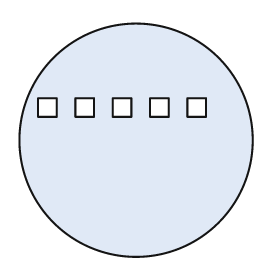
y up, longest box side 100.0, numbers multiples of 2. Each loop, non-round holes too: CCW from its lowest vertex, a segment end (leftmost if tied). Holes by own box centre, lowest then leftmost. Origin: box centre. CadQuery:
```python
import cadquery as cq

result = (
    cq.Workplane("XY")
    .moveTo(0.0, 0.0)
    .circle(50.0)
    .moveTo(-42.0, 10.0)
    .lineTo(-34.0, 10.0)
    .lineTo(-34.0, 18.0)
    .lineTo(-42.0, 18.0)
    .close()
    .moveTo(-26.0, 10.0)
    .lineTo(-18.0, 10.0)
    .lineTo(-18.0, 18.0)
    .lineTo(-26.0, 18.0)
    .close()
    .moveTo(-10.0, 10.0)
    .lineTo(-2.0, 10.0)
    .lineTo(-2.0, 18.0)
    .lineTo(-10.0, 18.0)
    .close()
    .moveTo(6.0, 10.0)
    .lineTo(14.0, 10.0)
    .lineTo(14.0, 18.0)
    .lineTo(6.0, 18.0)
    .close()
    .moveTo(22.0, 10.0)
    .lineTo(30.0, 10.0)
    .lineTo(30.0, 18.0)
    .lineTo(22.0, 18.0)
    .close()
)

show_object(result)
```